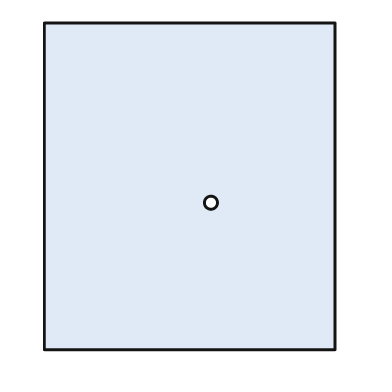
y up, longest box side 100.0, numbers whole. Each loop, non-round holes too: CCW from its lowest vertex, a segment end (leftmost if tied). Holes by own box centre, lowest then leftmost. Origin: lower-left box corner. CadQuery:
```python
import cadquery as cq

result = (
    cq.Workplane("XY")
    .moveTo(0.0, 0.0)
    .lineTo(89.0, 0.0)
    .lineTo(89.0, 100.0)
    .lineTo(0.0, 100.0)
    .close()
    .moveTo(51.0, 45.0)
    .circle(2.0)
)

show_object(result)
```